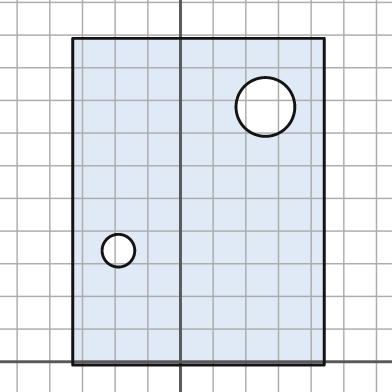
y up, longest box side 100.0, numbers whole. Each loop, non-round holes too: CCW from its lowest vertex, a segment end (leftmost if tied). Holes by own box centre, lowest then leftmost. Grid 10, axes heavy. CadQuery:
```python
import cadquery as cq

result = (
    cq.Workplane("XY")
    .moveTo(-33.0, -1.0)
    .lineTo(44.0, -1.0)
    .lineTo(44.0, 99.0)
    .lineTo(-33.0, 99.0)
    .close()
    .moveTo(-19.0, 34.0)
    .circle(5.0)
    .moveTo(26.0, 78.0)
    .circle(9.0)
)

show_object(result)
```